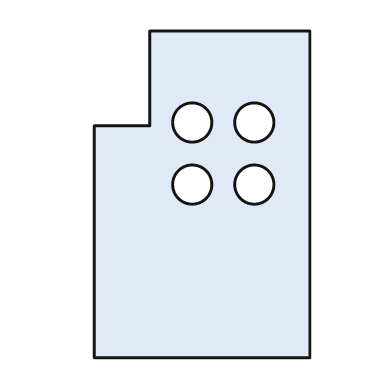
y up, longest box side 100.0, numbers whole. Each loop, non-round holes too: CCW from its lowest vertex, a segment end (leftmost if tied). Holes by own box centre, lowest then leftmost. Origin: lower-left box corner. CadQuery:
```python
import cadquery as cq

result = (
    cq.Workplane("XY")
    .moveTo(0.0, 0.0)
    .lineTo(66.0, 0.0)
    .lineTo(66.0, 100.0)
    .lineTo(17.0, 100.0)
    .lineTo(17.0, 71.0)
    .lineTo(0.0, 71.0)
    .close()
    .moveTo(30.0, 53.0)
    .circle(6.0)
    .moveTo(49.0, 53.0)
    .circle(6.0)
    .moveTo(30.0, 72.0)
    .circle(6.0)
    .moveTo(49.0, 72.0)
    .circle(6.0)
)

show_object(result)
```